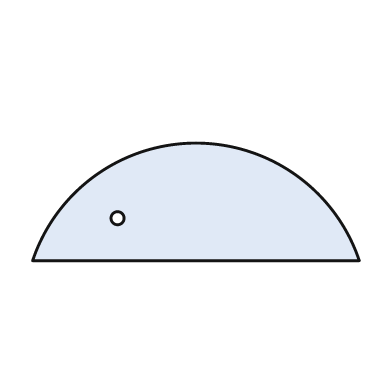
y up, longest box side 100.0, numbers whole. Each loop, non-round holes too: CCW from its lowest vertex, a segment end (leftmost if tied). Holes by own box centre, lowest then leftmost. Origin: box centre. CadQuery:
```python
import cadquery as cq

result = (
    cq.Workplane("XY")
    .moveTo(-50.0, -18.0)
    .lineTo(50.0, -18.0)
    .threePointArc((0.0, 18.0), (-50.0, -18.0))
    .close()
    .moveTo(-24.0, -5.0)
    .circle(2.0)
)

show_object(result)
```